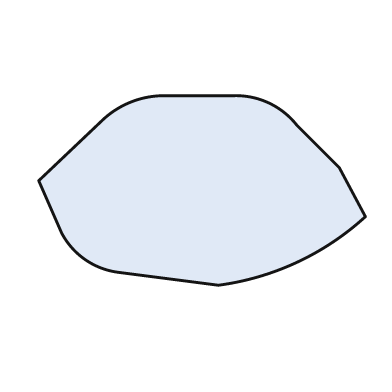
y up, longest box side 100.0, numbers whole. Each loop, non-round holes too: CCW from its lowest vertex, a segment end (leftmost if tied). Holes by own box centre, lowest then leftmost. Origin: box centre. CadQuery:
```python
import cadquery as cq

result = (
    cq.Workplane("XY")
    .moveTo(5.0, -29.0)
    .threePointArc((29.0, -22.0), (50.0, -8.0))
    .lineTo(42.0, 7.0)
    .lineTo(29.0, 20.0)
    .threePointArc((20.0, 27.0), (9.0, 29.0))
    .lineTo(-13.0, 29.0)
    .threePointArc((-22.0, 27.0), (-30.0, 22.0))
    .lineTo(-50.0, 3.0)
    .lineTo(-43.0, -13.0)
    .threePointArc((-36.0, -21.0), (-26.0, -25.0))
    .close()
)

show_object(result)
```